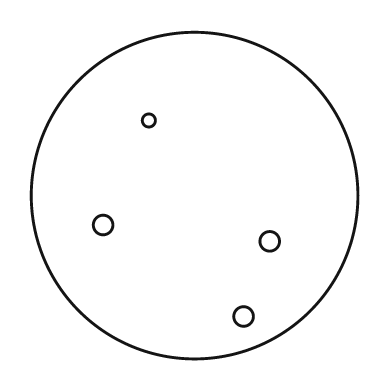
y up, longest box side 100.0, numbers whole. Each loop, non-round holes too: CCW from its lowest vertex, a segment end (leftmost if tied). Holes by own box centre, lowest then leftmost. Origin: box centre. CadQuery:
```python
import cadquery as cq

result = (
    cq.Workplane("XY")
    .moveTo(0.0, 0.0)
    .circle(50.0)
    .moveTo(15.0, -37.0)
    .circle(3.0)
    .moveTo(23.0, -14.0)
    .circle(3.0)
    .moveTo(-28.0, -9.0)
    .circle(3.0)
    .moveTo(-14.0, 23.0)
    .circle(2.0)
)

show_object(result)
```